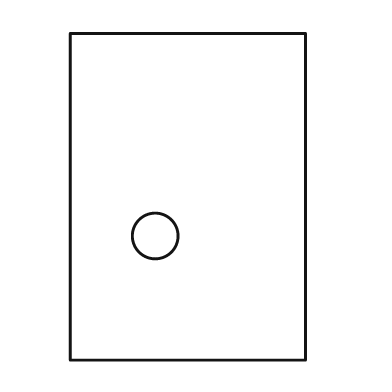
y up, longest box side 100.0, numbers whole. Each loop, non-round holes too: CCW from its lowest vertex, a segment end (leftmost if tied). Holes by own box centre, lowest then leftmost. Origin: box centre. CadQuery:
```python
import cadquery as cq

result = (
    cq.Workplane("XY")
    .moveTo(-36.0, -50.0)
    .lineTo(36.0, -50.0)
    .lineTo(36.0, 50.0)
    .lineTo(-36.0, 50.0)
    .close()
    .moveTo(-10.0, -12.0)
    .circle(7.0)
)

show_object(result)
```